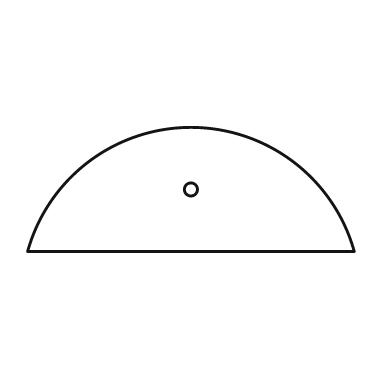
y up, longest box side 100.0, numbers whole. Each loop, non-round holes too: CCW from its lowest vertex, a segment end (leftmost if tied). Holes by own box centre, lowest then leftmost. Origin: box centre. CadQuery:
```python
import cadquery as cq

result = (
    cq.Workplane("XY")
    .moveTo(-50.0, -19.0)
    .lineTo(50.0, -19.0)
    .threePointArc((0.0, 19.0), (-50.0, -19.0))
    .close()
    .moveTo(0.0, 0.0)
    .circle(2.0)
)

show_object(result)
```